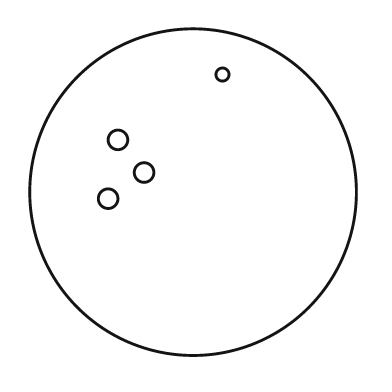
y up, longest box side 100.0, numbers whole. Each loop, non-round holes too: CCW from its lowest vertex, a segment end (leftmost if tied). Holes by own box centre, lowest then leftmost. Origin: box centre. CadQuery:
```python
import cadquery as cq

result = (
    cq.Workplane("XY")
    .moveTo(0.0, 0.0)
    .circle(50.0)
    .moveTo(-26.0, -2.0)
    .circle(3.0)
    .moveTo(-15.0, 6.0)
    .circle(3.0)
    .moveTo(-23.0, 16.0)
    .circle(3.0)
    .moveTo(9.0, 36.0)
    .circle(2.0)
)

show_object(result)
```